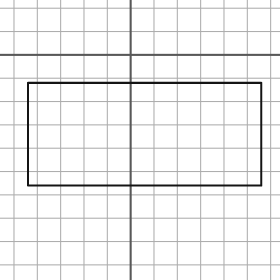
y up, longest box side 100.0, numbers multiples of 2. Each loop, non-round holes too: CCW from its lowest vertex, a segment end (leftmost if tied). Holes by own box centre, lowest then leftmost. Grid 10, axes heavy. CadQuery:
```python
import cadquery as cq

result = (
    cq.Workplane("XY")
    .moveTo(-44.0, -56.0)
    .lineTo(56.0, -56.0)
    .lineTo(56.0, -12.0)
    .lineTo(-44.0, -12.0)
    .close()
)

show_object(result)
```